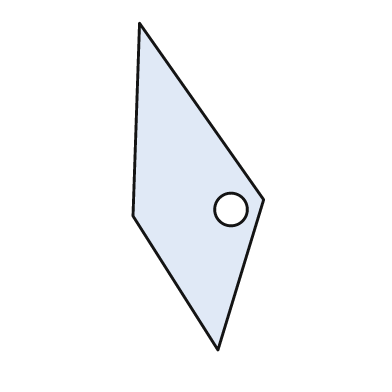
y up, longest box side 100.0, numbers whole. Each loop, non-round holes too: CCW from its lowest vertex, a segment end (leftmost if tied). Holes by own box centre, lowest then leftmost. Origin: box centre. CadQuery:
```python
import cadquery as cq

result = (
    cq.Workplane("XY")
    .moveTo(6.0, -50.0)
    .lineTo(20.0, -4.0)
    .lineTo(-18.0, 50.0)
    .lineTo(-20.0, -9.0)
    .close()
    .moveTo(10.0, -7.0)
    .circle(5.0)
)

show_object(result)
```